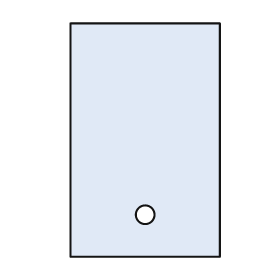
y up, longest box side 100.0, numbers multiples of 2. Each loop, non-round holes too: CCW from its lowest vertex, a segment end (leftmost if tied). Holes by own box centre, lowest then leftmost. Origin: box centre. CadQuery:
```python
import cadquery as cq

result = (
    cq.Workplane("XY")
    .moveTo(-32.0, -50.0)
    .lineTo(32.0, -50.0)
    .lineTo(32.0, 50.0)
    .lineTo(-32.0, 50.0)
    .close()
    .moveTo(0.0, -32.0)
    .circle(4.0)
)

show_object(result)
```